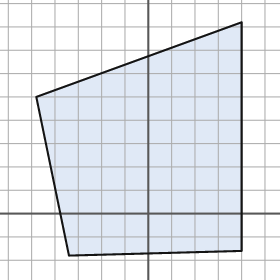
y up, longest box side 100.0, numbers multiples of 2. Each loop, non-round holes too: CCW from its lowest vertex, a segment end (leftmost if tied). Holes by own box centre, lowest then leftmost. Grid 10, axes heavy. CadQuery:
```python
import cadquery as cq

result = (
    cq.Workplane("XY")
    .moveTo(-34.0, -18.0)
    .lineTo(40.0, -16.0)
    .lineTo(40.0, 82.0)
    .lineTo(-48.0, 50.0)
    .close()
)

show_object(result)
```